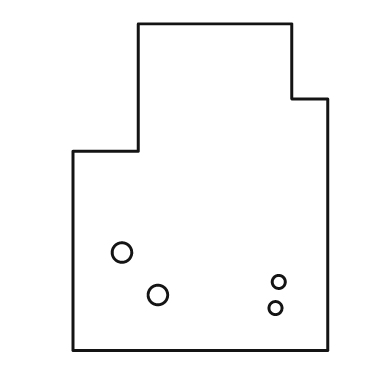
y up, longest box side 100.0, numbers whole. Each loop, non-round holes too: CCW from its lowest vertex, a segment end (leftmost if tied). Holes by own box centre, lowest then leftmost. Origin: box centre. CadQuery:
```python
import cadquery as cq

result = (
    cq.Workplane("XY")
    .moveTo(-39.0, -50.0)
    .lineTo(39.0, -50.0)
    .lineTo(39.0, 27.0)
    .lineTo(28.0, 27.0)
    .lineTo(28.0, 50.0)
    .lineTo(-19.0, 50.0)
    .lineTo(-19.0, 11.0)
    .lineTo(-39.0, 11.0)
    .close()
    .moveTo(23.0, -37.0)
    .circle(2.0)
    .moveTo(-13.0, -33.0)
    .circle(3.0)
    .moveTo(24.0, -29.0)
    .circle(2.0)
    .moveTo(-24.0, -20.0)
    .circle(3.0)
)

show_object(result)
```